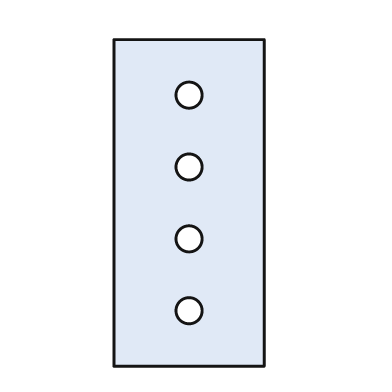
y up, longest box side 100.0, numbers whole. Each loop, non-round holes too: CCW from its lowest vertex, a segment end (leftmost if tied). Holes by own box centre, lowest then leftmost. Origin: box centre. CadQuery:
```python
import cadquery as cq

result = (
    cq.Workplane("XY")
    .moveTo(-23.0, -50.0)
    .lineTo(23.0, -50.0)
    .lineTo(23.0, 50.0)
    .lineTo(-23.0, 50.0)
    .close()
    .moveTo(0.0, -33.0)
    .circle(4.0)
    .moveTo(0.0, -11.0)
    .circle(4.0)
    .moveTo(0.0, 11.0)
    .circle(4.0)
    .moveTo(0.0, 33.0)
    .circle(4.0)
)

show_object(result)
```